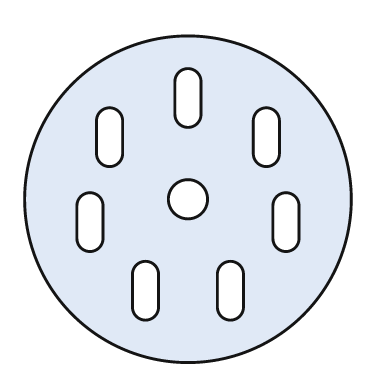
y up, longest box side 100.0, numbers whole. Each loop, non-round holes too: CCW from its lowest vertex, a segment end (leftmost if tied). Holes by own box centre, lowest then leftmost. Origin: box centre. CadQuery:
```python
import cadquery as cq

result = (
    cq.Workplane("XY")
    .moveTo(0.0, 0.0)
    .circle(50.0)
    .moveTo(-17.0, -33.0)
    .threePointArc((-13.0, -37.0), (-9.0, -33.0))
    .lineTo(-9.0, -23.0)
    .threePointArc((-13.0, -19.0), (-17.0, -23.0))
    .close()
    .moveTo(9.0, -33.0)
    .threePointArc((13.0, -37.0), (17.0, -33.0))
    .lineTo(17.0, -23.0)
    .threePointArc((13.0, -19.0), (9.0, -23.0))
    .close()
    .moveTo(-34.0, -12.0)
    .threePointArc((-30.0, -16.0), (-26.0, -12.0))
    .lineTo(-26.0, -2.0)
    .threePointArc((-30.0, 2.0), (-34.0, -2.0))
    .close()
    .moveTo(26.0, -12.0)
    .threePointArc((30.0, -16.0), (34.0, -12.0))
    .lineTo(34.0, -2.0)
    .threePointArc((30.0, 2.0), (26.0, -2.0))
    .close()
    .moveTo(0.0, 0.0)
    .circle(6.0)
    .moveTo(-28.0, 14.0)
    .threePointArc((-24.0, 10.0), (-20.0, 14.0))
    .lineTo(-20.0, 24.0)
    .threePointArc((-24.0, 28.0), (-28.0, 24.0))
    .close()
    .moveTo(20.0, 14.0)
    .threePointArc((24.0, 10.0), (28.0, 14.0))
    .lineTo(28.0, 24.0)
    .threePointArc((24.0, 28.0), (20.0, 24.0))
    .close()
    .moveTo(-4.0, 26.0)
    .threePointArc((0.0, 22.0), (4.0, 26.0))
    .lineTo(4.0, 36.0)
    .threePointArc((0.0, 40.0), (-4.0, 36.0))
    .close()
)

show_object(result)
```